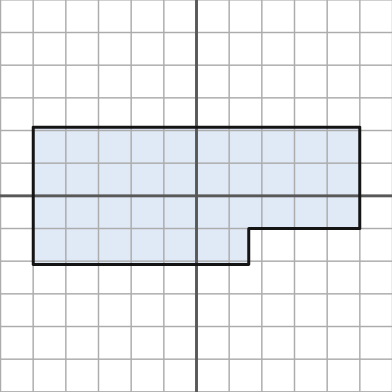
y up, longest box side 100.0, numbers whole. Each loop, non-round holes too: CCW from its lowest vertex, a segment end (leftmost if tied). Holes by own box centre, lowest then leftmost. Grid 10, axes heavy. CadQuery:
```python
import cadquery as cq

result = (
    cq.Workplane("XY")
    .moveTo(-50.0, -21.0)
    .lineTo(16.0, -21.0)
    .lineTo(16.0, -10.0)
    .lineTo(50.0, -10.0)
    .lineTo(50.0, 21.0)
    .lineTo(-50.0, 21.0)
    .close()
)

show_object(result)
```